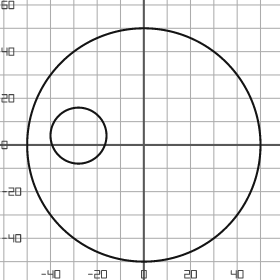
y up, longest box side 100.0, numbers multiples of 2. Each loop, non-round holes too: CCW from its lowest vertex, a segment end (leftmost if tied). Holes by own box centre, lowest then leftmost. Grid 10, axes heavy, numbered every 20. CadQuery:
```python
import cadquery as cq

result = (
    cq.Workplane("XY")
    .moveTo(0.0, 0.0)
    .circle(50.0)
    .moveTo(-28.0, 4.0)
    .circle(12.0)
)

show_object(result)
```